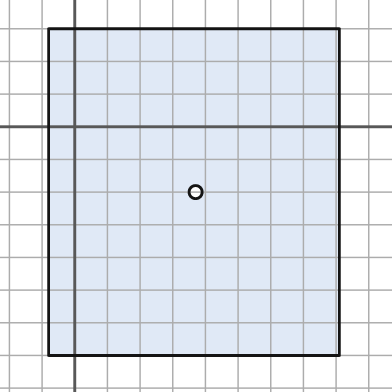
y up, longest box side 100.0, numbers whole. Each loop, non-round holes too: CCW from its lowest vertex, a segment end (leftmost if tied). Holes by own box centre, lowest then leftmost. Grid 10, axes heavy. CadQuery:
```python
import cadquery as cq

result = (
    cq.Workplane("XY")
    .moveTo(-8.0, -70.0)
    .lineTo(81.0, -70.0)
    .lineTo(81.0, 30.0)
    .lineTo(-8.0, 30.0)
    .close()
    .moveTo(37.0, -20.0)
    .circle(2.0)
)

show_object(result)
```